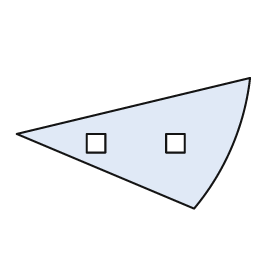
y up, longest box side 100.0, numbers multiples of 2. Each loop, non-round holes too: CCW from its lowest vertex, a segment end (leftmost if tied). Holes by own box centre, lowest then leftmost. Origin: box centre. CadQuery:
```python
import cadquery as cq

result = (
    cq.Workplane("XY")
    .moveTo(26.0, -28.0)
    .threePointArc((42.0, -2.0), (50.0, 28.0))
    .lineTo(-50.0, 4.0)
    .close()
    .moveTo(-20.0, -4.0)
    .lineTo(-12.0, -4.0)
    .lineTo(-12.0, 4.0)
    .lineTo(-20.0, 4.0)
    .close()
    .moveTo(14.0, -4.0)
    .lineTo(22.0, -4.0)
    .lineTo(22.0, 4.0)
    .lineTo(14.0, 4.0)
    .close()
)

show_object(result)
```